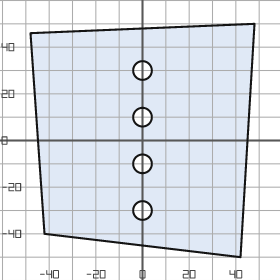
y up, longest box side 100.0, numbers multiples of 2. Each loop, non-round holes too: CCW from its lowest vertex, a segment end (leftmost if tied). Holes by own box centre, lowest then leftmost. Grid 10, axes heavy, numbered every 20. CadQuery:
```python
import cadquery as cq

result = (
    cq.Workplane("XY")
    .moveTo(42.0, -50.0)
    .lineTo(48.0, 50.0)
    .lineTo(-48.0, 46.0)
    .lineTo(-42.0, -40.0)
    .close()
    .moveTo(0.0, -30.0)
    .circle(4.0)
    .moveTo(0.0, -10.0)
    .circle(4.0)
    .moveTo(0.0, 10.0)
    .circle(4.0)
    .moveTo(0.0, 30.0)
    .circle(4.0)
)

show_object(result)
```